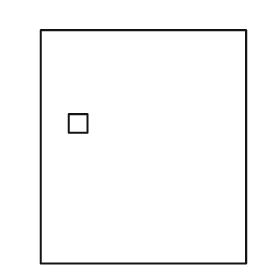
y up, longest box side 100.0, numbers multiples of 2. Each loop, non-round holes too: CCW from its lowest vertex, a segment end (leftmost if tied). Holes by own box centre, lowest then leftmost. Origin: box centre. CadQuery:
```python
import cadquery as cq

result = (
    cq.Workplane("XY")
    .moveTo(-44.0, -50.0)
    .lineTo(44.0, -50.0)
    .lineTo(44.0, 50.0)
    .lineTo(-44.0, 50.0)
    .close()
    .moveTo(-32.0, 6.0)
    .lineTo(-24.0, 6.0)
    .lineTo(-24.0, 14.0)
    .lineTo(-32.0, 14.0)
    .close()
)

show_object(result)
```